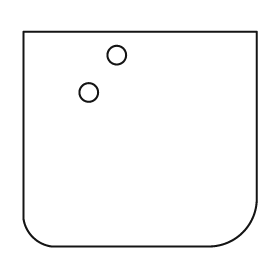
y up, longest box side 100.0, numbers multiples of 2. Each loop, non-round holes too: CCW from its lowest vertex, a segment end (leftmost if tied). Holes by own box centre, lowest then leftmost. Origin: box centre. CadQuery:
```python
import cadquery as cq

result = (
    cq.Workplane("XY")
    .moveTo(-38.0, -46.0)
    .lineTo(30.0, -46.0)
    .threePointArc((44.0, -40.0), (50.0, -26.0))
    .lineTo(50.0, 46.0)
    .lineTo(-50.0, 46.0)
    .lineTo(-50.0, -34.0)
    .threePointArc((-46.0, -42.0), (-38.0, -46.0))
    .close()
    .moveTo(-22.0, 20.0)
    .circle(4.0)
    .moveTo(-10.0, 36.0)
    .circle(4.0)
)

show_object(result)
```